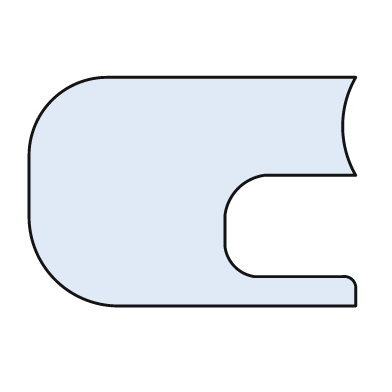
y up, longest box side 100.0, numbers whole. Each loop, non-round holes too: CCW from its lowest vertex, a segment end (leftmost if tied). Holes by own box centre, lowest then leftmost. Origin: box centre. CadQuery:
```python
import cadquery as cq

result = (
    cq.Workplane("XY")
    .moveTo(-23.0, -35.0)
    .lineTo(50.0, -35.0)
    .lineTo(50.0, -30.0)
    .threePointArc((49.0, -27.0), (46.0, -26.0))
    .lineTo(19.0, -26.0)
    .threePointArc((13.0, -23.0), (10.0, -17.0))
    .lineTo(10.0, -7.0)
    .threePointArc((14.0, 1.0), (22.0, 5.0))
    .lineTo(50.0, 5.0)
    .threePointArc((46.0, 20.0), (50.0, 35.0))
    .lineTo(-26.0, 35.0)
    .threePointArc((-43.0, 28.0), (-50.0, 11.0))
    .lineTo(-50.0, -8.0)
    .threePointArc((-42.0, -27.0), (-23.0, -35.0))
    .close()
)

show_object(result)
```